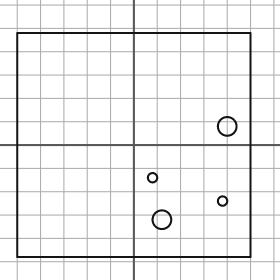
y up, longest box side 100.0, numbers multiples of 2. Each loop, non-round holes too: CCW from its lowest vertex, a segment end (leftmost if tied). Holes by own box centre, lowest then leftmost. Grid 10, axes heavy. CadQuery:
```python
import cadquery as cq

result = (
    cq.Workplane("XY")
    .moveTo(-50.0, -48.0)
    .lineTo(50.0, -48.0)
    .lineTo(50.0, 48.0)
    .lineTo(-50.0, 48.0)
    .close()
    .moveTo(12.0, -32.0)
    .circle(4.0)
    .moveTo(38.0, -24.0)
    .circle(2.0)
    .moveTo(8.0, -14.0)
    .circle(2.0)
    .moveTo(40.0, 8.0)
    .circle(4.0)
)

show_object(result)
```